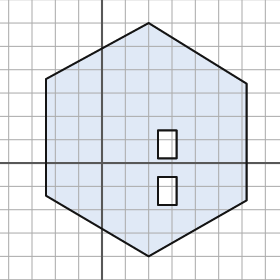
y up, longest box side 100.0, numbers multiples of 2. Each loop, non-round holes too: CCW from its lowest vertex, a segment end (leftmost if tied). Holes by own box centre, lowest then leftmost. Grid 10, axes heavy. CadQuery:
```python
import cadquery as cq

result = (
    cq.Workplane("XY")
    .moveTo(20.0, -40.0)
    .lineTo(62.0, -16.0)
    .lineTo(62.0, 34.0)
    .lineTo(20.0, 60.0)
    .lineTo(-24.0, 36.0)
    .lineTo(-24.0, -14.0)
    .close()
    .moveTo(24.0, -18.0)
    .lineTo(32.0, -18.0)
    .lineTo(32.0, -6.0)
    .lineTo(24.0, -6.0)
    .close()
    .moveTo(24.0, 2.0)
    .lineTo(32.0, 2.0)
    .lineTo(32.0, 14.0)
    .lineTo(24.0, 14.0)
    .close()
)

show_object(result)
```